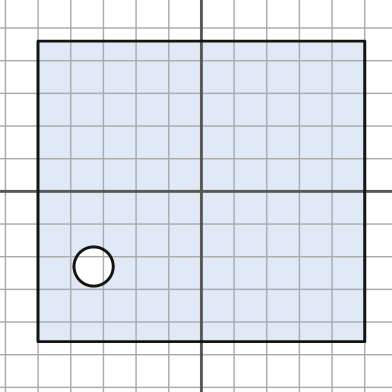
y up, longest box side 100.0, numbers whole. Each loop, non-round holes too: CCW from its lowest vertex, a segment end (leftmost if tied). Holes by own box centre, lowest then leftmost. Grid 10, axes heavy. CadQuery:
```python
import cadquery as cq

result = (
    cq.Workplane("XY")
    .moveTo(-50.0, -46.0)
    .lineTo(50.0, -46.0)
    .lineTo(50.0, 46.0)
    .lineTo(-50.0, 46.0)
    .close()
    .moveTo(-33.0, -23.0)
    .circle(6.0)
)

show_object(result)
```